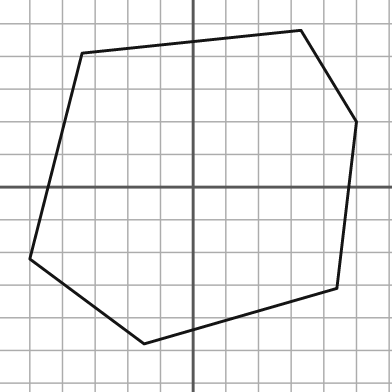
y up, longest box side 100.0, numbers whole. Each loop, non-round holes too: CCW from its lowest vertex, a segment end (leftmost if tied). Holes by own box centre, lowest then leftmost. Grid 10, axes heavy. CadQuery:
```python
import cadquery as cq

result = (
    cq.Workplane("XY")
    .moveTo(-15.0, -48.0)
    .lineTo(44.0, -31.0)
    .lineTo(50.0, 20.0)
    .lineTo(33.0, 48.0)
    .lineTo(-34.0, 41.0)
    .lineTo(-50.0, -22.0)
    .close()
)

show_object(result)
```